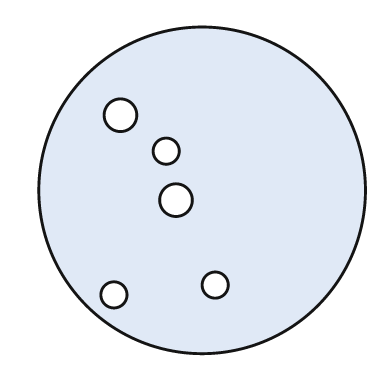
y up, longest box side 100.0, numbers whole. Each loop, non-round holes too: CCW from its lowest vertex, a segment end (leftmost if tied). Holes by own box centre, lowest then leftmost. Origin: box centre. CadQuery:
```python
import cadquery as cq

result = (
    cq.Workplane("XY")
    .moveTo(0.0, 0.0)
    .circle(50.0)
    .moveTo(-27.0, -32.0)
    .circle(4.0)
    .moveTo(4.0, -29.0)
    .circle(4.0)
    .moveTo(-8.0, -3.0)
    .circle(5.0)
    .moveTo(-11.0, 12.0)
    .circle(4.0)
    .moveTo(-25.0, 23.0)
    .circle(5.0)
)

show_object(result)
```